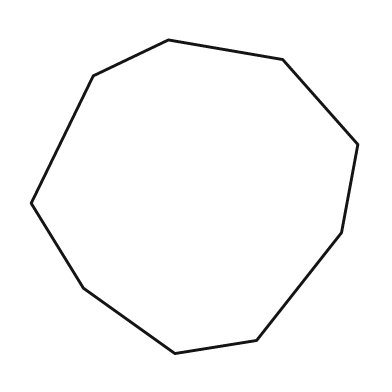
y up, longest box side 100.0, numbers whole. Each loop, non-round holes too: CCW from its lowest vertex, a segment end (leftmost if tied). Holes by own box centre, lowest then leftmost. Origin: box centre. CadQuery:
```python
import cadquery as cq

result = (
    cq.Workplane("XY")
    .moveTo(-6.0, -48.0)
    .lineTo(19.0, -44.0)
    .lineTo(45.0, -11.0)
    .lineTo(50.0, 16.0)
    .lineTo(27.0, 42.0)
    .lineTo(-8.0, 48.0)
    .lineTo(-31.0, 37.0)
    .lineTo(-50.0, -2.0)
    .lineTo(-34.0, -28.0)
    .close()
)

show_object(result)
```